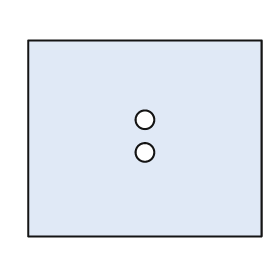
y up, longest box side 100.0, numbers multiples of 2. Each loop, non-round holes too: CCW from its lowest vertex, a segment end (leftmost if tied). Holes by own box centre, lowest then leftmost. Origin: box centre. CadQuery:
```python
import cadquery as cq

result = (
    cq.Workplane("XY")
    .moveTo(-50.0, -42.0)
    .lineTo(50.0, -42.0)
    .lineTo(50.0, 42.0)
    .lineTo(-50.0, 42.0)
    .close()
    .moveTo(0.0, -6.0)
    .circle(4.0)
    .moveTo(0.0, 8.0)
    .circle(4.0)
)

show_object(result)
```